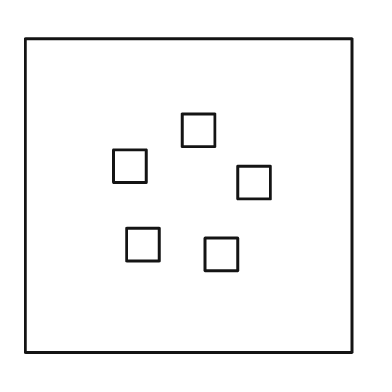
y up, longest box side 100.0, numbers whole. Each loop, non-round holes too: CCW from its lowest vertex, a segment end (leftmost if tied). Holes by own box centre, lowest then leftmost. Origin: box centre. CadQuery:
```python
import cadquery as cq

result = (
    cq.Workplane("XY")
    .moveTo(-50.0, -48.0)
    .lineTo(50.0, -48.0)
    .lineTo(50.0, 48.0)
    .lineTo(-50.0, 48.0)
    .close()
    .moveTo(5.0, -23.0)
    .lineTo(15.0, -23.0)
    .lineTo(15.0, -13.0)
    .lineTo(5.0, -13.0)
    .close()
    .moveTo(-19.0, -20.0)
    .lineTo(-9.0, -20.0)
    .lineTo(-9.0, -10.0)
    .lineTo(-19.0, -10.0)
    .close()
    .moveTo(15.0, -1.0)
    .lineTo(25.0, -1.0)
    .lineTo(25.0, 9.0)
    .lineTo(15.0, 9.0)
    .close()
    .moveTo(-23.0, 4.0)
    .lineTo(-13.0, 4.0)
    .lineTo(-13.0, 14.0)
    .lineTo(-23.0, 14.0)
    .close()
    .moveTo(-2.0, 15.0)
    .lineTo(8.0, 15.0)
    .lineTo(8.0, 25.0)
    .lineTo(-2.0, 25.0)
    .close()
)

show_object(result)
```